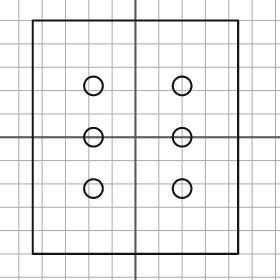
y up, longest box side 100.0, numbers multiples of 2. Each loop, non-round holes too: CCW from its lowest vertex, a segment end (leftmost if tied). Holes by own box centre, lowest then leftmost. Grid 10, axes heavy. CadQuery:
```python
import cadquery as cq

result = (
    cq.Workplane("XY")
    .moveTo(-44.0, -50.0)
    .lineTo(44.0, -50.0)
    .lineTo(44.0, 50.0)
    .lineTo(-44.0, 50.0)
    .close()
    .moveTo(-18.0, -22.0)
    .circle(4.0)
    .moveTo(20.0, -22.0)
    .circle(4.0)
    .moveTo(-18.0, 0.0)
    .circle(4.0)
    .moveTo(20.0, 0.0)
    .circle(4.0)
    .moveTo(-18.0, 22.0)
    .circle(4.0)
    .moveTo(20.0, 22.0)
    .circle(4.0)
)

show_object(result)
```